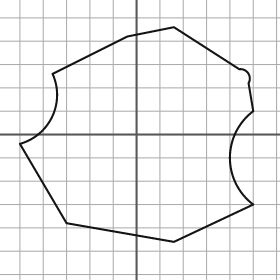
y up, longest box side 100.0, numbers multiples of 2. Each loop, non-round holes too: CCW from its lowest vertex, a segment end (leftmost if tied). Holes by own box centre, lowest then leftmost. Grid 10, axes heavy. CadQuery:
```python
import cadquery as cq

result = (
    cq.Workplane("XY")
    .moveTo(16.0, -46.0)
    .lineTo(50.0, -30.0)
    .threePointArc((40.0, -10.0), (50.0, 10.0))
    .lineTo(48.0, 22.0)
    .threePointArc((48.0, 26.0), (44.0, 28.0))
    .lineTo(16.0, 46.0)
    .lineTo(-4.0, 42.0)
    .lineTo(-36.0, 26.0)
    .threePointArc((-36.0, 8.0), (-50.0, -4.0))
    .lineTo(-30.0, -38.0)
    .close()
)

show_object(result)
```